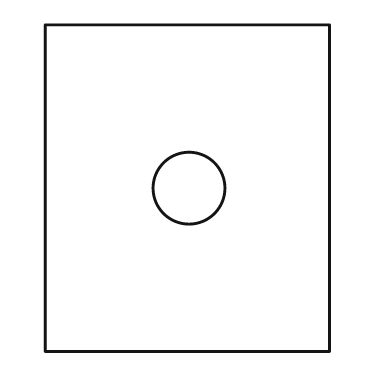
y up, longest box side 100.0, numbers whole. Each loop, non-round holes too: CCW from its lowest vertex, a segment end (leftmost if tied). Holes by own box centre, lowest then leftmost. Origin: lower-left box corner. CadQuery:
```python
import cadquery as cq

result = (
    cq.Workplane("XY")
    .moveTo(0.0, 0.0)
    .lineTo(87.0, 0.0)
    .lineTo(87.0, 100.0)
    .lineTo(0.0, 100.0)
    .close()
    .moveTo(44.0, 50.0)
    .circle(11.0)
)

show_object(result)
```